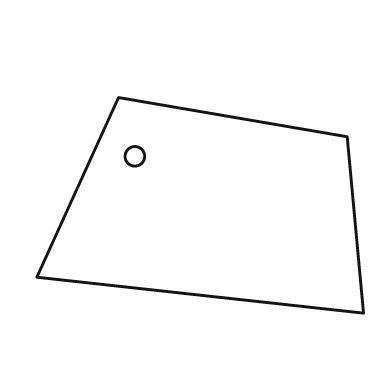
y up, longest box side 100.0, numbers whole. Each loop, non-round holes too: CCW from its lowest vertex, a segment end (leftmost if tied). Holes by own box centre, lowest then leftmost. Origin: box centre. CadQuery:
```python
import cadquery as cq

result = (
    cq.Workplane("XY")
    .moveTo(50.0, -33.0)
    .lineTo(45.0, 21.0)
    .lineTo(-25.0, 33.0)
    .lineTo(-50.0, -22.0)
    .close()
    .moveTo(-20.0, 15.0)
    .circle(3.0)
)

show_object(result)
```